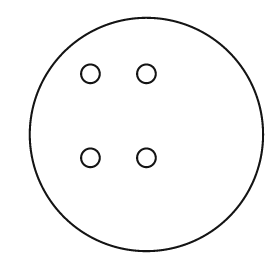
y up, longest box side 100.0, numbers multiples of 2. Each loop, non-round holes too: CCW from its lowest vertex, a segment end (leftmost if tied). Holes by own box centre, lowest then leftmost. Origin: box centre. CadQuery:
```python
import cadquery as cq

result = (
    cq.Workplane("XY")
    .moveTo(0.0, 0.0)
    .circle(50.0)
    .moveTo(-24.0, -10.0)
    .circle(4.0)
    .moveTo(0.0, -10.0)
    .circle(4.0)
    .moveTo(-24.0, 26.0)
    .circle(4.0)
    .moveTo(0.0, 26.0)
    .circle(4.0)
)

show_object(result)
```